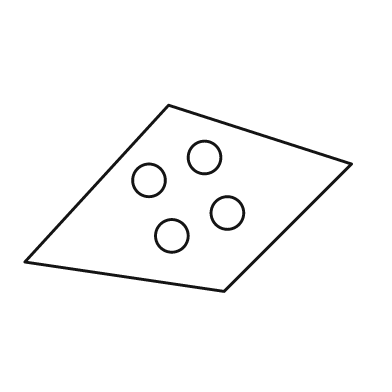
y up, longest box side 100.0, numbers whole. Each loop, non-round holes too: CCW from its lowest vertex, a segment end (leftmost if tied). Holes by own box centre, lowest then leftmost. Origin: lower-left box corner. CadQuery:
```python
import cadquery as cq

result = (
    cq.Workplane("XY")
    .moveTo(61.0, 0.0)
    .lineTo(100.0, 39.0)
    .lineTo(44.0, 57.0)
    .lineTo(0.0, 9.0)
    .close()
    .moveTo(45.0, 17.0)
    .circle(5.0)
    .moveTo(62.0, 24.0)
    .circle(5.0)
    .moveTo(38.0, 34.0)
    .circle(5.0)
    .moveTo(55.0, 41.0)
    .circle(5.0)
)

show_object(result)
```